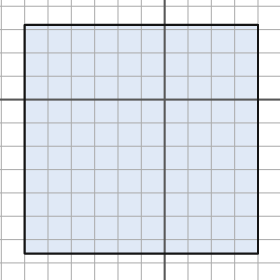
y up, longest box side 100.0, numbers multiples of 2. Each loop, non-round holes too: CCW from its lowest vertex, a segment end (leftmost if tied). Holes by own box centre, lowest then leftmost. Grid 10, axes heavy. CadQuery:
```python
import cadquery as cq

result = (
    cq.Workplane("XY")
    .moveTo(-60.0, -66.0)
    .lineTo(40.0, -66.0)
    .lineTo(40.0, 32.0)
    .lineTo(-60.0, 32.0)
    .close()
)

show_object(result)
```